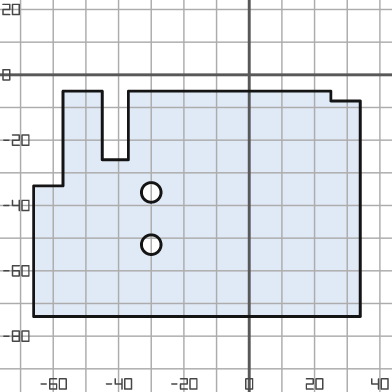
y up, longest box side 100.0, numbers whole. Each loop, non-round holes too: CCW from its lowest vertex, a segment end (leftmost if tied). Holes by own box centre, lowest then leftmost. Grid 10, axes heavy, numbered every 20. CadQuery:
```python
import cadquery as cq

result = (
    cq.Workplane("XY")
    .moveTo(-66.0, -74.0)
    .lineTo(34.0, -74.0)
    .lineTo(34.0, -8.0)
    .lineTo(25.0, -8.0)
    .lineTo(25.0, -5.0)
    .lineTo(-37.0, -5.0)
    .lineTo(-37.0, -26.0)
    .lineTo(-45.0, -26.0)
    .lineTo(-45.0, -5.0)
    .lineTo(-57.0, -5.0)
    .lineTo(-57.0, -34.0)
    .lineTo(-66.0, -34.0)
    .close()
    .moveTo(-30.0, -52.0)
    .circle(3.0)
    .moveTo(-30.0, -36.0)
    .circle(3.0)
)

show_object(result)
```